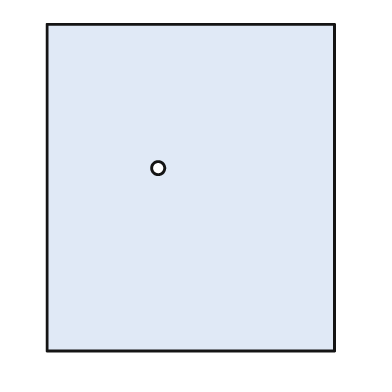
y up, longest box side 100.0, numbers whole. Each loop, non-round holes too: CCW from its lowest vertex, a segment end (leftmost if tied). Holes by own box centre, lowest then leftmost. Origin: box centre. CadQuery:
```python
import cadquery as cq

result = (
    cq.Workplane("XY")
    .moveTo(-44.0, -50.0)
    .lineTo(44.0, -50.0)
    .lineTo(44.0, 50.0)
    .lineTo(-44.0, 50.0)
    .close()
    .moveTo(-10.0, 6.0)
    .circle(2.0)
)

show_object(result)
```